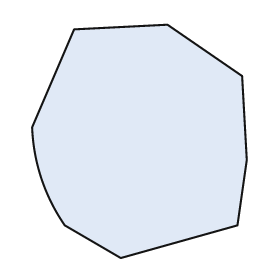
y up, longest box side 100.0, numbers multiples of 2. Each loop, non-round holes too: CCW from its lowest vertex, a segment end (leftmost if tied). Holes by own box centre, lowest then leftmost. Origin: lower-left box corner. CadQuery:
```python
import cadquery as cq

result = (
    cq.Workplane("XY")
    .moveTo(38.0, 0.0)
    .lineTo(88.0, 14.0)
    .lineTo(92.0, 42.0)
    .lineTo(90.0, 78.0)
    .lineTo(58.0, 100.0)
    .lineTo(18.0, 98.0)
    .lineTo(0.0, 56.0)
    .threePointArc((4.0, 34.0), (14.0, 14.0))
    .close()
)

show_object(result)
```